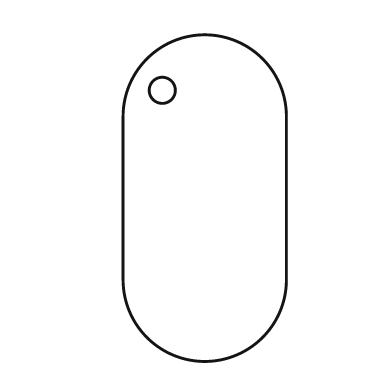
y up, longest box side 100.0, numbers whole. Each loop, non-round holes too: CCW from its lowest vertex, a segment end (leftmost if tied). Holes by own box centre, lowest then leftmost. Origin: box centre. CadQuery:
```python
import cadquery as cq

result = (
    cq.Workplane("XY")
    .moveTo(-25.0, -25.0)
    .threePointArc((0.0, -50.0), (25.0, -25.0))
    .lineTo(25.0, 25.0)
    .threePointArc((0.0, 50.0), (-25.0, 25.0))
    .close()
    .moveTo(-13.0, 33.0)
    .circle(4.0)
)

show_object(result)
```